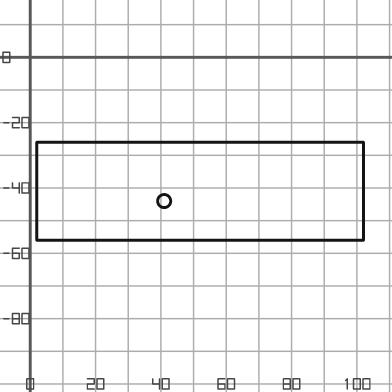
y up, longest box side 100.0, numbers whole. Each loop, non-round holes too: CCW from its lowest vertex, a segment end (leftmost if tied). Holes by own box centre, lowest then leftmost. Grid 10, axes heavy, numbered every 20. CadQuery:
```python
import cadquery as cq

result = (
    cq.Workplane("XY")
    .moveTo(2.0, -56.0)
    .lineTo(102.0, -56.0)
    .lineTo(102.0, -26.0)
    .lineTo(2.0, -26.0)
    .close()
    .moveTo(41.0, -44.0)
    .circle(2.0)
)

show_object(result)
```